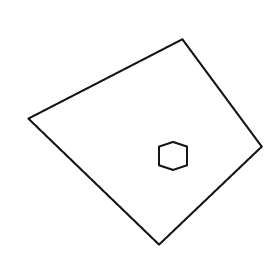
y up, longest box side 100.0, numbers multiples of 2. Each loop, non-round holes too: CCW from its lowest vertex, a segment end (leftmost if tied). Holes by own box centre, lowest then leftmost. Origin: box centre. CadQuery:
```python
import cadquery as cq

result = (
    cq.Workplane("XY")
    .moveTo(6.0, -44.0)
    .lineTo(50.0, -2.0)
    .lineTo(16.0, 44.0)
    .lineTo(-50.0, 10.0)
    .close()
    .moveTo(12.0, -12.0)
    .lineTo(18.0, -10.0)
    .lineTo(18.0, -2.0)
    .lineTo(12.0, 0.0)
    .lineTo(6.0, -2.0)
    .lineTo(6.0, -10.0)
    .close()
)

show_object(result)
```